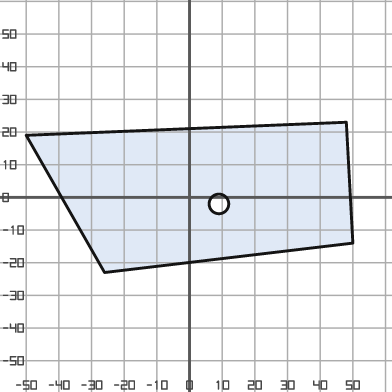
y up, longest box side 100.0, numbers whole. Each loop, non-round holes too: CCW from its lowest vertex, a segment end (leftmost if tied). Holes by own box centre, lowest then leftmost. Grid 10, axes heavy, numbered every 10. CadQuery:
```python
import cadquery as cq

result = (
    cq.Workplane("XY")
    .moveTo(-26.0, -23.0)
    .lineTo(50.0, -14.0)
    .lineTo(48.0, 23.0)
    .lineTo(-50.0, 19.0)
    .close()
    .moveTo(9.0, -2.0)
    .circle(3.0)
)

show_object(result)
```